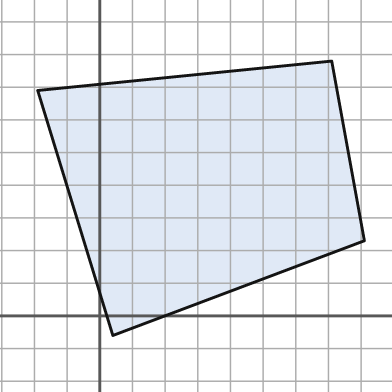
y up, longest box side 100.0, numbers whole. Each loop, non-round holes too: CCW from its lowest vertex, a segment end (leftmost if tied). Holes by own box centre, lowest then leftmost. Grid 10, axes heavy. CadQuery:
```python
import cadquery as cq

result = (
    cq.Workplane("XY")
    .moveTo(4.0, -6.0)
    .lineTo(81.0, 23.0)
    .lineTo(71.0, 78.0)
    .lineTo(-19.0, 69.0)
    .close()
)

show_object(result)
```